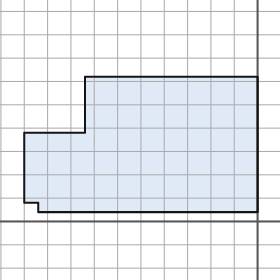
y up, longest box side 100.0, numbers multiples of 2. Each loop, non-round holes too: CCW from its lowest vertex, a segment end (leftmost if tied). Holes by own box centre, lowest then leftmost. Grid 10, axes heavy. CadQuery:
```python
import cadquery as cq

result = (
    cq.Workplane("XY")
    .moveTo(-94.0, 4.0)
    .lineTo(0.0, 4.0)
    .lineTo(0.0, 62.0)
    .lineTo(-74.0, 62.0)
    .lineTo(-74.0, 38.0)
    .lineTo(-100.0, 38.0)
    .lineTo(-100.0, 8.0)
    .lineTo(-94.0, 8.0)
    .close()
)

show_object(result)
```